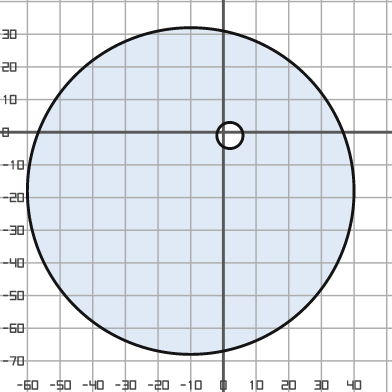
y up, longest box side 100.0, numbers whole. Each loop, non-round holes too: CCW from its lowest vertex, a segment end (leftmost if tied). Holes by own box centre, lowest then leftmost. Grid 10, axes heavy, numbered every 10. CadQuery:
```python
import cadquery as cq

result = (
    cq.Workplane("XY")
    .moveTo(-10.0, -18.0)
    .circle(50.0)
    .moveTo(2.0, -1.0)
    .circle(4.0)
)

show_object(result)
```